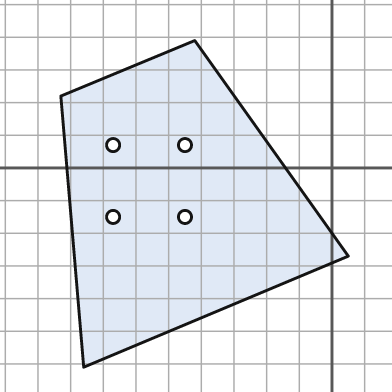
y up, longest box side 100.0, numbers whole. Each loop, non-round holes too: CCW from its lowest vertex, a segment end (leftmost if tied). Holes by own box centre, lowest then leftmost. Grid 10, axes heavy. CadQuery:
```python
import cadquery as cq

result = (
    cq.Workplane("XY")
    .moveTo(-76.0, -61.0)
    .lineTo(5.0, -27.0)
    .lineTo(-42.0, 39.0)
    .lineTo(-83.0, 22.0)
    .close()
    .moveTo(-67.0, -15.0)
    .circle(2.0)
    .moveTo(-45.0, -15.0)
    .circle(2.0)
    .moveTo(-67.0, 7.0)
    .circle(2.0)
    .moveTo(-45.0, 7.0)
    .circle(2.0)
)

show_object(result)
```